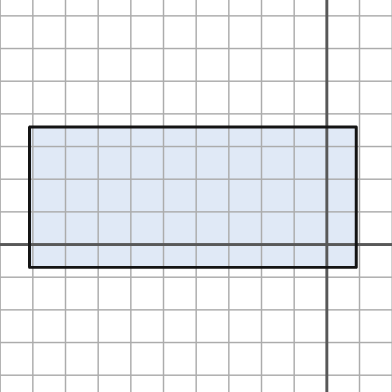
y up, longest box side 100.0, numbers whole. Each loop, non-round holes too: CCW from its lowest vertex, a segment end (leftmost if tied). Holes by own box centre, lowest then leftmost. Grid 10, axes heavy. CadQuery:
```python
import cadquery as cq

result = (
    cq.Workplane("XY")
    .moveTo(-91.0, -7.0)
    .lineTo(9.0, -7.0)
    .lineTo(9.0, 36.0)
    .lineTo(-91.0, 36.0)
    .close()
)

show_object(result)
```